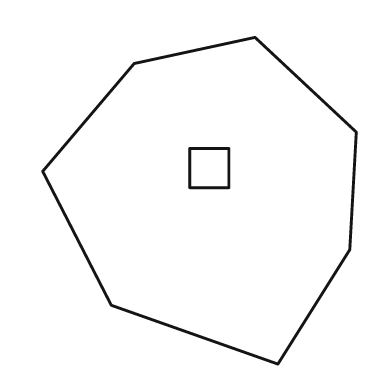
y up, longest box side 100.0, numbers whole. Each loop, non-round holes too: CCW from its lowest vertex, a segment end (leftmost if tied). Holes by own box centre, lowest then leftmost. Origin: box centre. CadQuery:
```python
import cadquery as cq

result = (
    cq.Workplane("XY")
    .moveTo(24.0, -50.0)
    .lineTo(46.0, -15.0)
    .lineTo(48.0, 21.0)
    .lineTo(17.0, 50.0)
    .lineTo(-20.0, 42.0)
    .lineTo(-48.0, 9.0)
    .lineTo(-27.0, -32.0)
    .close()
    .moveTo(-3.0, 4.0)
    .lineTo(9.0, 4.0)
    .lineTo(9.0, 16.0)
    .lineTo(-3.0, 16.0)
    .close()
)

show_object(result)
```